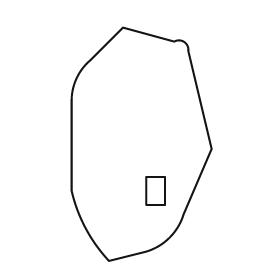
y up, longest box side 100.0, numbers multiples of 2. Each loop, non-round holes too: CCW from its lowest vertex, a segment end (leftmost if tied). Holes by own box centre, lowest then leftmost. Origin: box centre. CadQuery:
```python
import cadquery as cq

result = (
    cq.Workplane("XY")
    .moveTo(-14.0, -50.0)
    .lineTo(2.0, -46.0)
    .threePointArc((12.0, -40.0), (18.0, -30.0))
    .lineTo(30.0, -2.0)
    .lineTo(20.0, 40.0)
    .threePointArc((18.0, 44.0), (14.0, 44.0))
    .lineTo(-8.0, 50.0)
    .lineTo(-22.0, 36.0)
    .threePointArc((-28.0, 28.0), (-30.0, 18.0))
    .lineTo(-30.0, -20.0)
    .threePointArc((-24.0, -36.0), (-14.0, -50.0))
    .close()
    .moveTo(2.0, -26.0)
    .lineTo(10.0, -26.0)
    .lineTo(10.0, -14.0)
    .lineTo(2.0, -14.0)
    .close()
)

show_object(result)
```